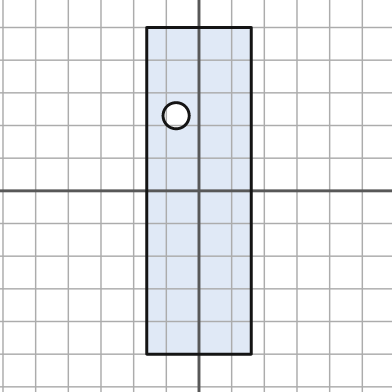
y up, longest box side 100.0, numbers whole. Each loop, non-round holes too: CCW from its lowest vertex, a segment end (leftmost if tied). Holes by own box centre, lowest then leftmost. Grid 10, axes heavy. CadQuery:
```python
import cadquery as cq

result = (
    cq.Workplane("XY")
    .moveTo(-16.0, -50.0)
    .lineTo(16.0, -50.0)
    .lineTo(16.0, 50.0)
    .lineTo(-16.0, 50.0)
    .close()
    .moveTo(-7.0, 23.0)
    .circle(4.0)
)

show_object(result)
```